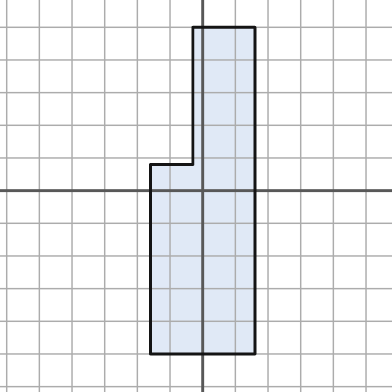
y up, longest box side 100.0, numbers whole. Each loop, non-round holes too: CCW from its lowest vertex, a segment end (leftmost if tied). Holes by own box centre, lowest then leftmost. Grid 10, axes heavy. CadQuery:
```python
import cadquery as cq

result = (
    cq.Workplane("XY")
    .moveTo(-16.0, -50.0)
    .lineTo(16.0, -50.0)
    .lineTo(16.0, 50.0)
    .lineTo(-3.0, 50.0)
    .lineTo(-3.0, 8.0)
    .lineTo(-16.0, 8.0)
    .close()
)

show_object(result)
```